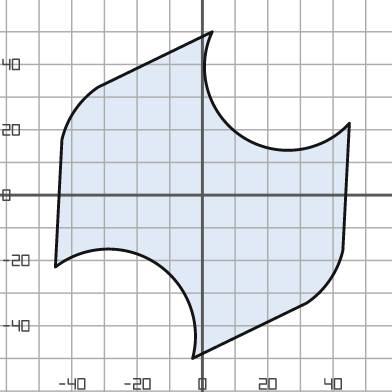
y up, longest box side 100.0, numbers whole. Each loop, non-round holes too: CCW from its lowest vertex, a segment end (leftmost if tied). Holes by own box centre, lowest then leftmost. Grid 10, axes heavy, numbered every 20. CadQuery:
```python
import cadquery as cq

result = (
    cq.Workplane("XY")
    .moveTo(-3.0, -50.0)
    .lineTo(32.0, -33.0)
    .threePointArc((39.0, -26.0), (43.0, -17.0))
    .lineTo(45.0, 22.0)
    .threePointArc((12.0, 18.0), (3.0, 50.0))
    .lineTo(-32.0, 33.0)
    .threePointArc((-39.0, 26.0), (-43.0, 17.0))
    .lineTo(-45.0, -22.0)
    .threePointArc((-14.0, -21.0), (-3.0, -50.0))
    .close()
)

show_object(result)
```